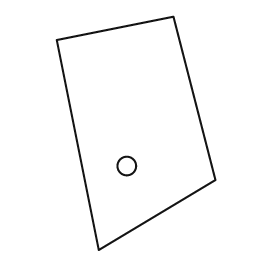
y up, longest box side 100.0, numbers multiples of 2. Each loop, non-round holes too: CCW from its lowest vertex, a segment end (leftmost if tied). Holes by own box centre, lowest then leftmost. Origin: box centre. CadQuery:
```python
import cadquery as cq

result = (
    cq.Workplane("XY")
    .moveTo(-16.0, -50.0)
    .lineTo(34.0, -20.0)
    .lineTo(16.0, 50.0)
    .lineTo(-34.0, 40.0)
    .close()
    .moveTo(-4.0, -14.0)
    .circle(4.0)
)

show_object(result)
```